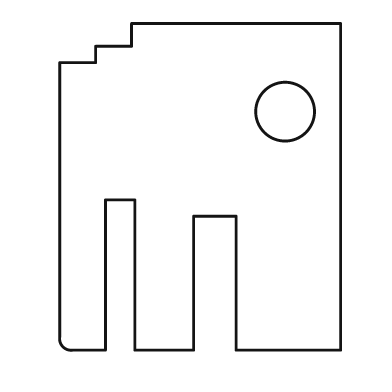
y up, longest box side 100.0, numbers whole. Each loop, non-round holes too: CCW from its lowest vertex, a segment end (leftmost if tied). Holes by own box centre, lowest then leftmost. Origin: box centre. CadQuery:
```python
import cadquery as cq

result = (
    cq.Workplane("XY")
    .moveTo(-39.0, -50.0)
    .lineTo(-29.0, -50.0)
    .lineTo(-29.0, -4.0)
    .lineTo(-20.0, -4.0)
    .lineTo(-20.0, -50.0)
    .lineTo(-2.0, -50.0)
    .lineTo(-2.0, -9.0)
    .lineTo(11.0, -9.0)
    .lineTo(11.0, -50.0)
    .lineTo(43.0, -50.0)
    .lineTo(43.0, 50.0)
    .lineTo(-21.0, 50.0)
    .lineTo(-21.0, 43.0)
    .lineTo(-32.0, 43.0)
    .lineTo(-32.0, 38.0)
    .lineTo(-43.0, 38.0)
    .lineTo(-43.0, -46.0)
    .threePointArc((-42.0, -49.0), (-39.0, -50.0))
    .close()
    .moveTo(26.0, 23.0)
    .circle(9.0)
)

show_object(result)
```